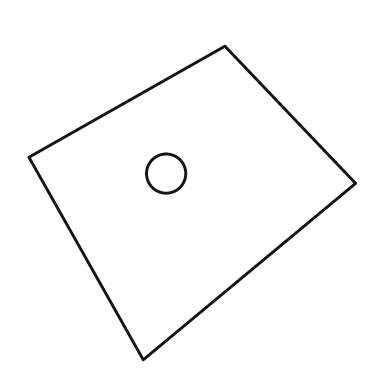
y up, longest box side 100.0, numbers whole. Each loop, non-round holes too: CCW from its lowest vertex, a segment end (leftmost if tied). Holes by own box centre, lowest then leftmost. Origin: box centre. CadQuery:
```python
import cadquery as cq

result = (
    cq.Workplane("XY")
    .moveTo(-15.0, -48.0)
    .lineTo(50.0, 6.0)
    .lineTo(10.0, 48.0)
    .lineTo(-50.0, 14.0)
    .close()
    .moveTo(-8.0, 9.0)
    .circle(6.0)
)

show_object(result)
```